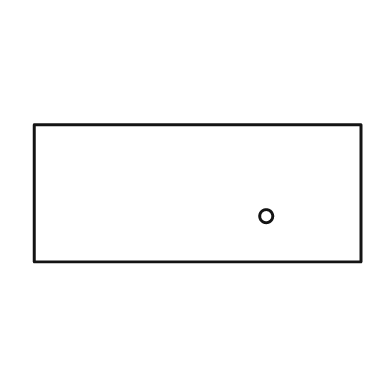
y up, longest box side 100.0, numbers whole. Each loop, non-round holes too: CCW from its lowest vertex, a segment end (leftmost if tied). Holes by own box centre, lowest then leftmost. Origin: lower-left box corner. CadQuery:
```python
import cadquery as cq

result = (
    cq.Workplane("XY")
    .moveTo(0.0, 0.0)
    .lineTo(100.0, 0.0)
    .lineTo(100.0, 42.0)
    .lineTo(0.0, 42.0)
    .close()
    .moveTo(71.0, 14.0)
    .circle(2.0)
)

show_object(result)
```